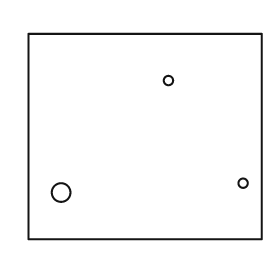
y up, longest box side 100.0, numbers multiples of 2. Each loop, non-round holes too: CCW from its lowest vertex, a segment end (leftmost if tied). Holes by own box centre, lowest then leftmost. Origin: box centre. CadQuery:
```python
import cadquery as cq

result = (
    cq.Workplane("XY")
    .moveTo(-50.0, -44.0)
    .lineTo(50.0, -44.0)
    .lineTo(50.0, 44.0)
    .lineTo(-50.0, 44.0)
    .close()
    .moveTo(-36.0, -24.0)
    .circle(4.0)
    .moveTo(42.0, -20.0)
    .circle(2.0)
    .moveTo(10.0, 24.0)
    .circle(2.0)
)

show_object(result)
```